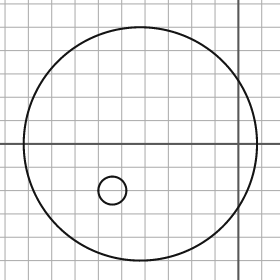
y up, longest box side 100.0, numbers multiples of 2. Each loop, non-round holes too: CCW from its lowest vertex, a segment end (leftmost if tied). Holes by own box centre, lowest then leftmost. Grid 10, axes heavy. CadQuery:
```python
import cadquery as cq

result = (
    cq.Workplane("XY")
    .moveTo(-42.0, 0.0)
    .circle(50.0)
    .moveTo(-54.0, -20.0)
    .circle(6.0)
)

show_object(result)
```